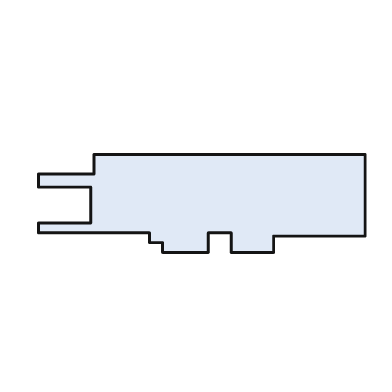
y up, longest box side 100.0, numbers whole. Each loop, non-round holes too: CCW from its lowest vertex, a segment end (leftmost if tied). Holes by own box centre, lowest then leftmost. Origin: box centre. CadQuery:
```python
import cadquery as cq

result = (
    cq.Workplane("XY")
    .moveTo(-12.0, -15.0)
    .lineTo(2.0, -15.0)
    .lineTo(2.0, -9.0)
    .lineTo(9.0, -9.0)
    .lineTo(9.0, -15.0)
    .lineTo(22.0, -15.0)
    .lineTo(22.0, -10.0)
    .lineTo(50.0, -10.0)
    .lineTo(50.0, 15.0)
    .lineTo(-33.0, 15.0)
    .lineTo(-33.0, 9.0)
    .lineTo(-50.0, 9.0)
    .lineTo(-50.0, 5.0)
    .lineTo(-34.0, 5.0)
    .lineTo(-34.0, -6.0)
    .lineTo(-50.0, -6.0)
    .lineTo(-50.0, -9.0)
    .lineTo(-16.0, -9.0)
    .lineTo(-16.0, -12.0)
    .lineTo(-12.0, -12.0)
    .close()
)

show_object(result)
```